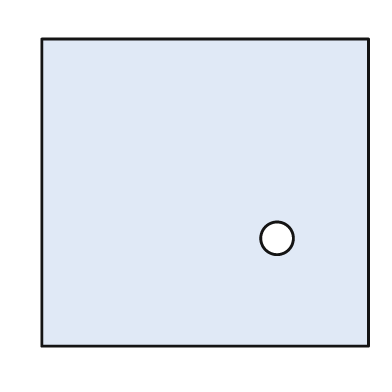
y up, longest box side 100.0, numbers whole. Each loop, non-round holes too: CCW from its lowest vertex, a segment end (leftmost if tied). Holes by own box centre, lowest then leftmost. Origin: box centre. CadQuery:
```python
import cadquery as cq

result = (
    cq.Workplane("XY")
    .moveTo(-50.0, -47.0)
    .lineTo(50.0, -47.0)
    .lineTo(50.0, 47.0)
    .lineTo(-50.0, 47.0)
    .close()
    .moveTo(22.0, -14.0)
    .circle(5.0)
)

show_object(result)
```